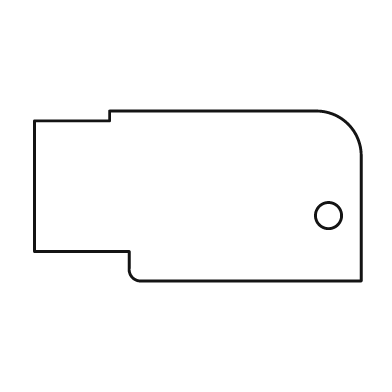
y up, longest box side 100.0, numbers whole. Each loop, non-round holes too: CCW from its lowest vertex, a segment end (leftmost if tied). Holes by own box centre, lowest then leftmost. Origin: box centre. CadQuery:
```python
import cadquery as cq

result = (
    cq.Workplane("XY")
    .moveTo(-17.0, -26.0)
    .lineTo(50.0, -26.0)
    .lineTo(50.0, 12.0)
    .threePointArc((46.0, 22.0), (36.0, 26.0))
    .lineTo(-27.0, 26.0)
    .lineTo(-27.0, 23.0)
    .lineTo(-50.0, 23.0)
    .lineTo(-50.0, -17.0)
    .lineTo(-21.0, -17.0)
    .lineTo(-21.0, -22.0)
    .threePointArc((-20.0, -25.0), (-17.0, -26.0))
    .close()
    .moveTo(40.0, -6.0)
    .circle(4.0)
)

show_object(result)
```